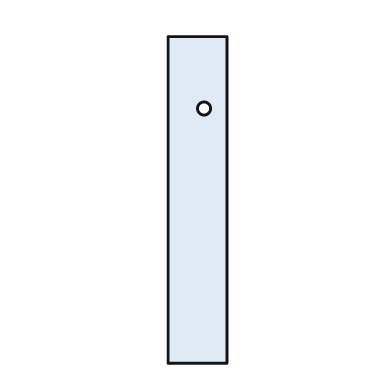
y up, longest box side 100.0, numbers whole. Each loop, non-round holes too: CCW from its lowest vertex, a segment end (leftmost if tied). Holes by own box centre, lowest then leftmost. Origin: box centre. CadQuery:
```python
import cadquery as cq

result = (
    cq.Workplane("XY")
    .moveTo(-9.0, -50.0)
    .lineTo(9.0, -50.0)
    .lineTo(9.0, 50.0)
    .lineTo(-9.0, 50.0)
    .close()
    .moveTo(2.0, 28.0)
    .circle(2.0)
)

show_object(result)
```